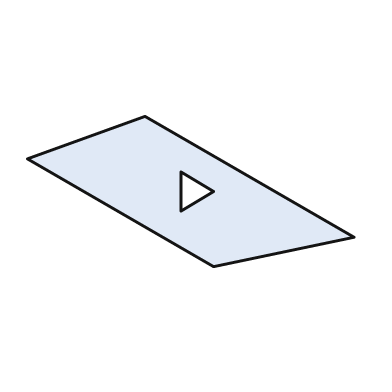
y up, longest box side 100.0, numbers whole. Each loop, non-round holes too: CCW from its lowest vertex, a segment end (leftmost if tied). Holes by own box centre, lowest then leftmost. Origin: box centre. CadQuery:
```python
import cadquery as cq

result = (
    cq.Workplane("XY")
    .moveTo(7.0, -23.0)
    .lineTo(50.0, -14.0)
    .lineTo(-14.0, 23.0)
    .lineTo(-50.0, 10.0)
    .close()
    .moveTo(-3.0, -6.0)
    .lineTo(7.0, 0.0)
    .lineTo(-3.0, 6.0)
    .close()
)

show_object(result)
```